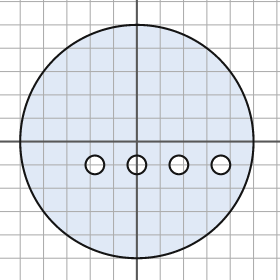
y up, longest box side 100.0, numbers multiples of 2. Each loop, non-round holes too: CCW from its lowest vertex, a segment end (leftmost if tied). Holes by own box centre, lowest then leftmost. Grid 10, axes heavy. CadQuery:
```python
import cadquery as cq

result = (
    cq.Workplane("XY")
    .moveTo(0.0, 0.0)
    .circle(50.0)
    .moveTo(-18.0, -10.0)
    .circle(4.0)
    .moveTo(0.0, -10.0)
    .circle(4.0)
    .moveTo(18.0, -10.0)
    .circle(4.0)
    .moveTo(36.0, -10.0)
    .circle(4.0)
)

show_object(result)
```